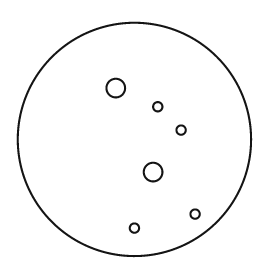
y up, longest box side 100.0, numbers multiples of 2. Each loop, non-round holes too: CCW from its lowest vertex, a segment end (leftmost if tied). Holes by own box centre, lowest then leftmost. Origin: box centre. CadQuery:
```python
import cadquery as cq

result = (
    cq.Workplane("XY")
    .moveTo(0.0, 0.0)
    .circle(50.0)
    .moveTo(0.0, -38.0)
    .circle(2.0)
    .moveTo(26.0, -32.0)
    .circle(2.0)
    .moveTo(8.0, -14.0)
    .circle(4.0)
    .moveTo(20.0, 4.0)
    .circle(2.0)
    .moveTo(10.0, 14.0)
    .circle(2.0)
    .moveTo(-8.0, 22.0)
    .circle(4.0)
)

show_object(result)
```